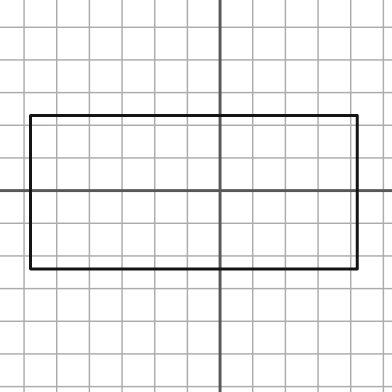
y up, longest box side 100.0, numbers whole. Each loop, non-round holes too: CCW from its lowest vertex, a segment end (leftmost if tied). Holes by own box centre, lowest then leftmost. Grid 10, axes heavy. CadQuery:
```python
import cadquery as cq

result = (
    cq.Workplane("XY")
    .moveTo(-58.0, -24.0)
    .lineTo(42.0, -24.0)
    .lineTo(42.0, 23.0)
    .lineTo(-58.0, 23.0)
    .close()
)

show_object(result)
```